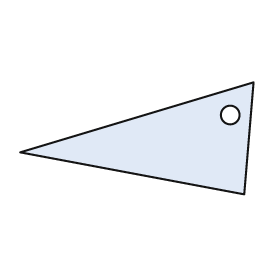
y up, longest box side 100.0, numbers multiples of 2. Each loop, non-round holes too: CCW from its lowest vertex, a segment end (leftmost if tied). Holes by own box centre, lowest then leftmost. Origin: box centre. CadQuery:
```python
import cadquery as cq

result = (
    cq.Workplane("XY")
    .moveTo(46.0, -24.0)
    .lineTo(50.0, 24.0)
    .lineTo(-50.0, -6.0)
    .close()
    .moveTo(40.0, 10.0)
    .circle(4.0)
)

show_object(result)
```